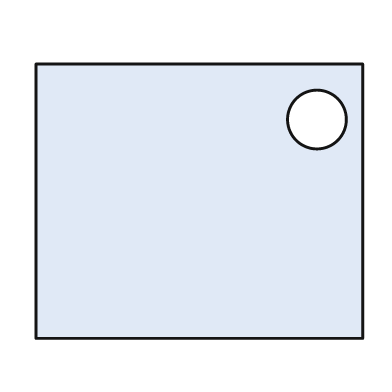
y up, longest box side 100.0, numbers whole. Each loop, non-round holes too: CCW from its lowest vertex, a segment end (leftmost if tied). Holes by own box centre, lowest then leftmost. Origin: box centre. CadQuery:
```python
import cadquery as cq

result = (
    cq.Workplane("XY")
    .moveTo(-50.0, -42.0)
    .lineTo(50.0, -42.0)
    .lineTo(50.0, 42.0)
    .lineTo(-50.0, 42.0)
    .close()
    .moveTo(36.0, 25.0)
    .circle(9.0)
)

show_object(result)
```